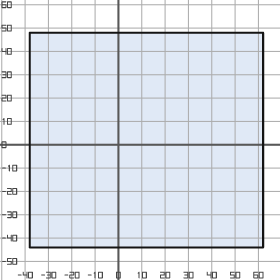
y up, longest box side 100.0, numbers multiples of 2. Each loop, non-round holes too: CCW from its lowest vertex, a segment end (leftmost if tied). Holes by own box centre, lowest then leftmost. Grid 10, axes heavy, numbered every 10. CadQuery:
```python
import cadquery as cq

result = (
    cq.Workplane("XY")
    .moveTo(-38.0, -44.0)
    .lineTo(62.0, -44.0)
    .lineTo(62.0, 48.0)
    .lineTo(-38.0, 48.0)
    .close()
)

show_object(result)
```